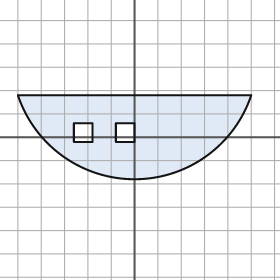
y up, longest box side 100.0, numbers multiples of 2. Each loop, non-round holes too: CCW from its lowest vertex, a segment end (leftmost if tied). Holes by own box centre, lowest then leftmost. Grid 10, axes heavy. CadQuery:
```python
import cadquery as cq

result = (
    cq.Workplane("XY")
    .moveTo(-50.0, 18.0)
    .threePointArc((0.0, -18.0), (50.0, 18.0))
    .close()
    .moveTo(-26.0, -2.0)
    .lineTo(-18.0, -2.0)
    .lineTo(-18.0, 6.0)
    .lineTo(-26.0, 6.0)
    .close()
    .moveTo(-8.0, -2.0)
    .lineTo(0.0, -2.0)
    .lineTo(0.0, 6.0)
    .lineTo(-8.0, 6.0)
    .close()
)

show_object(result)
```